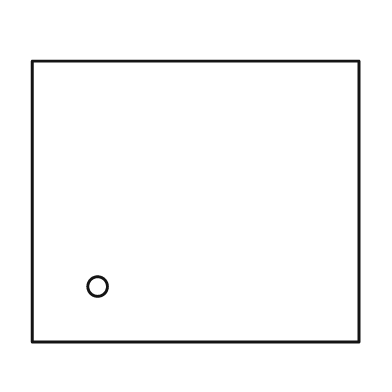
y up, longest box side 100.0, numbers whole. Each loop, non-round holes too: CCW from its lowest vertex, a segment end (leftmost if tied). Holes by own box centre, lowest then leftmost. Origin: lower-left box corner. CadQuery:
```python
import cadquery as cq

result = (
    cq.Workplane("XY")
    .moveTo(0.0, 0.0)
    .lineTo(100.0, 0.0)
    .lineTo(100.0, 86.0)
    .lineTo(0.0, 86.0)
    .close()
    .moveTo(20.0, 17.0)
    .circle(3.0)
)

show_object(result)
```